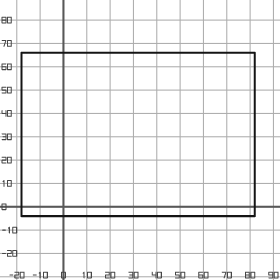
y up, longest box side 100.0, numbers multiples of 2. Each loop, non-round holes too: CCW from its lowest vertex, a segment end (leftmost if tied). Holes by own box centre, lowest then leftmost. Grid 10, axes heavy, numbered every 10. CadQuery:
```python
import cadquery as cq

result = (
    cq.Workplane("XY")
    .moveTo(-18.0, -4.0)
    .lineTo(82.0, -4.0)
    .lineTo(82.0, 66.0)
    .lineTo(-18.0, 66.0)
    .close()
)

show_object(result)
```